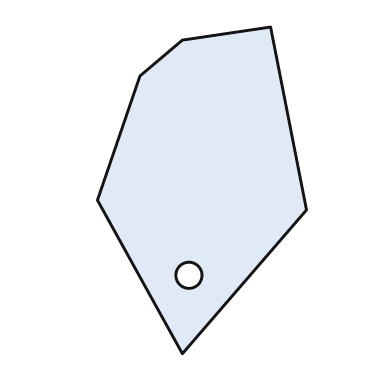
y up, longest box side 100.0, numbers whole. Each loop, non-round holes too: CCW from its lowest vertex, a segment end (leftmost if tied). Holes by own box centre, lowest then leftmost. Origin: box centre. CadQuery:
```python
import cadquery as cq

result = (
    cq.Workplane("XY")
    .moveTo(-6.0, -50.0)
    .lineTo(32.0, -6.0)
    .lineTo(21.0, 50.0)
    .lineTo(-6.0, 46.0)
    .lineTo(-19.0, 35.0)
    .lineTo(-32.0, -3.0)
    .close()
    .moveTo(-4.0, -26.0)
    .circle(4.0)
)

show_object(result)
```